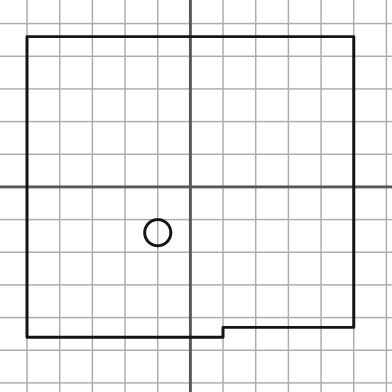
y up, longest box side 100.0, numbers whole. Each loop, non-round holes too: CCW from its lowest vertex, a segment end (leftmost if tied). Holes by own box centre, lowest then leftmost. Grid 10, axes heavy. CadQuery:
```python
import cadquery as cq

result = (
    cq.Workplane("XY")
    .moveTo(-50.0, -46.0)
    .lineTo(10.0, -46.0)
    .lineTo(10.0, -43.0)
    .lineTo(50.0, -43.0)
    .lineTo(50.0, 46.0)
    .lineTo(-50.0, 46.0)
    .close()
    .moveTo(-10.0, -14.0)
    .circle(4.0)
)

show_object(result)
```